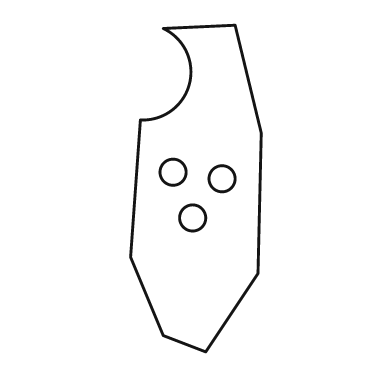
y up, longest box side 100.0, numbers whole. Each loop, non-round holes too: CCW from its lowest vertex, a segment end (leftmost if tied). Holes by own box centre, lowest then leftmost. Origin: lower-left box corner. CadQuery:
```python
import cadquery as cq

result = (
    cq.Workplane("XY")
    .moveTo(23.0, 0.0)
    .lineTo(39.0, 24.0)
    .lineTo(40.0, 67.0)
    .lineTo(32.0, 100.0)
    .lineTo(10.0, 99.0)
    .threePointArc((18.0, 82.0), (3.0, 71.0))
    .lineTo(0.0, 29.0)
    .lineTo(10.0, 5.0)
    .close()
    .moveTo(19.0, 41.0)
    .circle(4.0)
    .moveTo(28.0, 53.0)
    .circle(4.0)
    .moveTo(13.0, 55.0)
    .circle(4.0)
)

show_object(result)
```